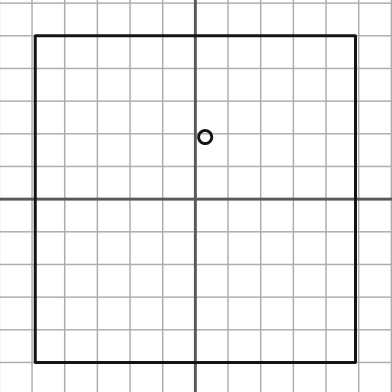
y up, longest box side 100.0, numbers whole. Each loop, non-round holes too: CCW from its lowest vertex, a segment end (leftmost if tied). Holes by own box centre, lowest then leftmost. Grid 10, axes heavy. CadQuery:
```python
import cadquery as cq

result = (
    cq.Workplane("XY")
    .moveTo(-49.0, -50.0)
    .lineTo(49.0, -50.0)
    .lineTo(49.0, 50.0)
    .lineTo(-49.0, 50.0)
    .close()
    .moveTo(3.0, 19.0)
    .circle(2.0)
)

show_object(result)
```